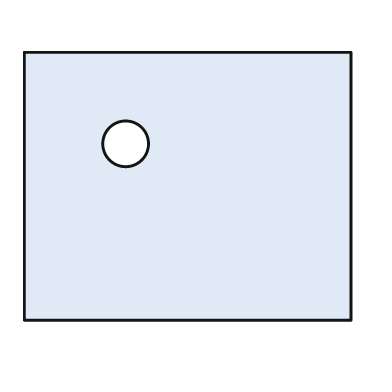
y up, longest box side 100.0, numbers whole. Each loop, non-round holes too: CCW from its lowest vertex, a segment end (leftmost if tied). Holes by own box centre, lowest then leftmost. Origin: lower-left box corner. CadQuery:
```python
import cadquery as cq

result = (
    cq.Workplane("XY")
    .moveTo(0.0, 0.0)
    .lineTo(100.0, 0.0)
    .lineTo(100.0, 82.0)
    .lineTo(0.0, 82.0)
    .close()
    .moveTo(31.0, 54.0)
    .circle(7.0)
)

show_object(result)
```